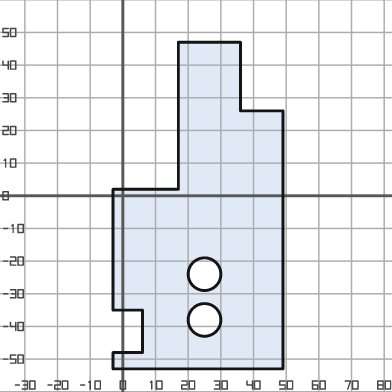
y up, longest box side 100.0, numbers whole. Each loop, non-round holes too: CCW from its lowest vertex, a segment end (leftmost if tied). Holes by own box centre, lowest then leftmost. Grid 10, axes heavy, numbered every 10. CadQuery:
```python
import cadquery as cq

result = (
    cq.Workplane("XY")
    .moveTo(-3.0, -53.0)
    .lineTo(49.0, -53.0)
    .lineTo(49.0, 26.0)
    .lineTo(36.0, 26.0)
    .lineTo(36.0, 47.0)
    .lineTo(17.0, 47.0)
    .lineTo(17.0, 2.0)
    .lineTo(-3.0, 2.0)
    .lineTo(-3.0, -35.0)
    .lineTo(6.0, -35.0)
    .lineTo(6.0, -48.0)
    .lineTo(-3.0, -48.0)
    .close()
    .moveTo(25.0, -38.0)
    .circle(5.0)
    .moveTo(25.0, -24.0)
    .circle(5.0)
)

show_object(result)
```